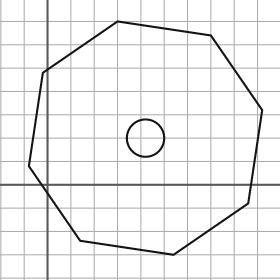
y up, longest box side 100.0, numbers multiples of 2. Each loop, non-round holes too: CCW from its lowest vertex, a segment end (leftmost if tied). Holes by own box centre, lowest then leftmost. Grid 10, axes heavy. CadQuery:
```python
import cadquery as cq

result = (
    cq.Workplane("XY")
    .moveTo(54.0, -30.0)
    .lineTo(86.0, -8.0)
    .lineTo(92.0, 32.0)
    .lineTo(70.0, 64.0)
    .lineTo(30.0, 70.0)
    .lineTo(-2.0, 48.0)
    .lineTo(-8.0, 8.0)
    .lineTo(14.0, -24.0)
    .close()
    .moveTo(42.0, 20.0)
    .circle(8.0)
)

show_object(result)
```